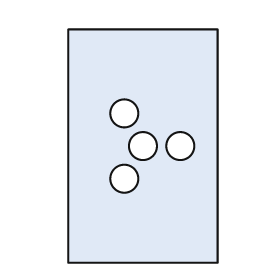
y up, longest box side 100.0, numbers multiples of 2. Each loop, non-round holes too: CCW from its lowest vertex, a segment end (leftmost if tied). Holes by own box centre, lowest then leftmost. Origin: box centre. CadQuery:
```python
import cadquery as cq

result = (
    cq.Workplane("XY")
    .moveTo(-32.0, -50.0)
    .lineTo(32.0, -50.0)
    .lineTo(32.0, 50.0)
    .lineTo(-32.0, 50.0)
    .close()
    .moveTo(-8.0, -14.0)
    .circle(6.0)
    .moveTo(0.0, 0.0)
    .circle(6.0)
    .moveTo(16.0, 0.0)
    .circle(6.0)
    .moveTo(-8.0, 14.0)
    .circle(6.0)
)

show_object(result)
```